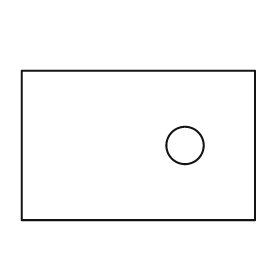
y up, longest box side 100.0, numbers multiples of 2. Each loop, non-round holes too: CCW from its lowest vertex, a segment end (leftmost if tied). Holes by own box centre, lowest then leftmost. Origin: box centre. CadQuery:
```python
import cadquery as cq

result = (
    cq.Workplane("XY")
    .moveTo(-50.0, -32.0)
    .lineTo(50.0, -32.0)
    .lineTo(50.0, 32.0)
    .lineTo(-50.0, 32.0)
    .close()
    .moveTo(20.0, 0.0)
    .circle(8.0)
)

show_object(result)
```